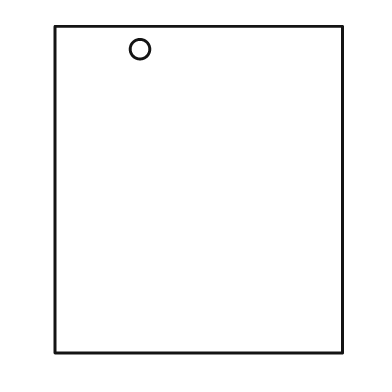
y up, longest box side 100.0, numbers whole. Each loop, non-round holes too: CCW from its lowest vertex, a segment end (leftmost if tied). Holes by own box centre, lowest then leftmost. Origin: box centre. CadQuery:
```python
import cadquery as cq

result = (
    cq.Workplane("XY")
    .moveTo(-44.0, -50.0)
    .lineTo(44.0, -50.0)
    .lineTo(44.0, 50.0)
    .lineTo(-44.0, 50.0)
    .close()
    .moveTo(-18.0, 43.0)
    .circle(3.0)
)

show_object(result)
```